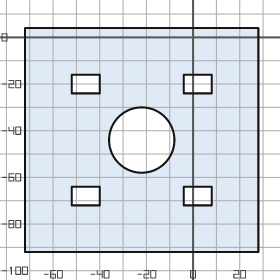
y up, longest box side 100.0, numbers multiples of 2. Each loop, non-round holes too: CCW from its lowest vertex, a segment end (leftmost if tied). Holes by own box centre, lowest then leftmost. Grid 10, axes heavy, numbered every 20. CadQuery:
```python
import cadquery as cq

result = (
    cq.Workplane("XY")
    .moveTo(-72.0, -92.0)
    .lineTo(28.0, -92.0)
    .lineTo(28.0, 4.0)
    .lineTo(-72.0, 4.0)
    .close()
    .moveTo(-52.0, -72.0)
    .lineTo(-40.0, -72.0)
    .lineTo(-40.0, -64.0)
    .lineTo(-52.0, -64.0)
    .close()
    .moveTo(-4.0, -72.0)
    .lineTo(8.0, -72.0)
    .lineTo(8.0, -64.0)
    .lineTo(-4.0, -64.0)
    .close()
    .moveTo(-22.0, -44.0)
    .circle(14.0)
    .moveTo(-52.0, -24.0)
    .lineTo(-40.0, -24.0)
    .lineTo(-40.0, -16.0)
    .lineTo(-52.0, -16.0)
    .close()
    .moveTo(-4.0, -24.0)
    .lineTo(8.0, -24.0)
    .lineTo(8.0, -16.0)
    .lineTo(-4.0, -16.0)
    .close()
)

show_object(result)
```